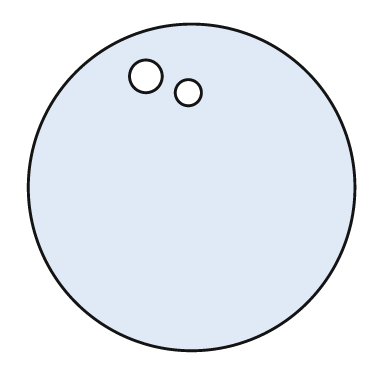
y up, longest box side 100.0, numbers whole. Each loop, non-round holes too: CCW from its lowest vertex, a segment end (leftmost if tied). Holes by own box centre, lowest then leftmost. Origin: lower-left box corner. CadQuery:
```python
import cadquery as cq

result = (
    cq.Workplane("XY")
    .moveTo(50.0, 50.0)
    .circle(50.0)
    .moveTo(49.0, 79.0)
    .circle(4.0)
    .moveTo(36.0, 84.0)
    .circle(5.0)
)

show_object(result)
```